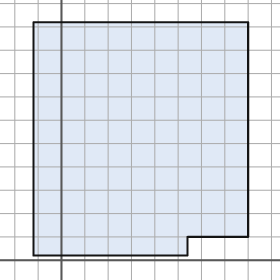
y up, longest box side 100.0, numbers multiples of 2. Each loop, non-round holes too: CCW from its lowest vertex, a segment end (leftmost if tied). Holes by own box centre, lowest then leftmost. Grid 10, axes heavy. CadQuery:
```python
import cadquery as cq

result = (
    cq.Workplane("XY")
    .moveTo(-12.0, 2.0)
    .lineTo(54.0, 2.0)
    .lineTo(54.0, 10.0)
    .lineTo(80.0, 10.0)
    .lineTo(80.0, 102.0)
    .lineTo(-12.0, 102.0)
    .close()
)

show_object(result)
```